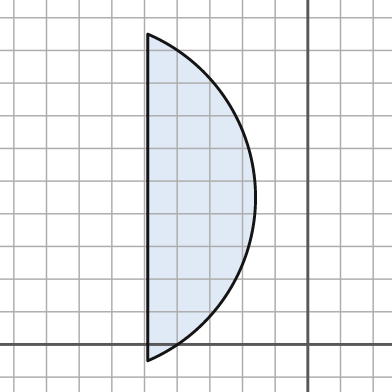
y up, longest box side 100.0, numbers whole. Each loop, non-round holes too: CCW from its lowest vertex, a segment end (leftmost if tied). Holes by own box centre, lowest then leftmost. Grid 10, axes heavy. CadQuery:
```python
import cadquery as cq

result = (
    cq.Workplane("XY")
    .moveTo(-49.0, -5.0)
    .threePointArc((-16.0, 45.0), (-49.0, 95.0))
    .close()
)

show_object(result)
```